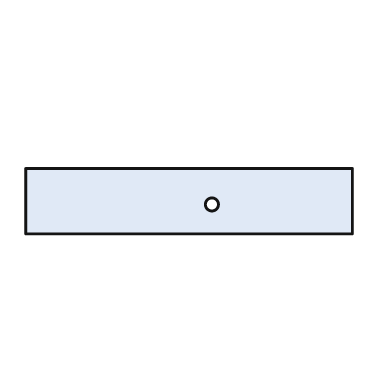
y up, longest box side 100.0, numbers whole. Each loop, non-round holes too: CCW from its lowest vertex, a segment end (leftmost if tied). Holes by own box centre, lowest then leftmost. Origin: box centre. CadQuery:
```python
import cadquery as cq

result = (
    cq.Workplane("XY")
    .moveTo(-50.0, -10.0)
    .lineTo(50.0, -10.0)
    .lineTo(50.0, 10.0)
    .lineTo(-50.0, 10.0)
    .close()
    .moveTo(7.0, -1.0)
    .circle(2.0)
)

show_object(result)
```